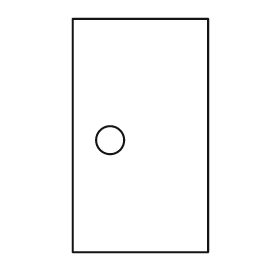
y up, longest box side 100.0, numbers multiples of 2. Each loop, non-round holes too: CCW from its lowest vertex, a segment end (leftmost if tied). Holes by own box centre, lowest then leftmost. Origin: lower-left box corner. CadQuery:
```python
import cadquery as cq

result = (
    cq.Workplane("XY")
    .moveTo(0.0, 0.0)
    .lineTo(58.0, 0.0)
    .lineTo(58.0, 100.0)
    .lineTo(0.0, 100.0)
    .close()
    .moveTo(16.0, 48.0)
    .circle(6.0)
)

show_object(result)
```